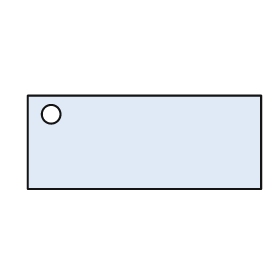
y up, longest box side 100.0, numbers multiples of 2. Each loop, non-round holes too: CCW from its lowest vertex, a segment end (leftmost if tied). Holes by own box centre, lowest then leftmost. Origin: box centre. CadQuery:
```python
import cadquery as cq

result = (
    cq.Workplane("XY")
    .moveTo(-50.0, -20.0)
    .lineTo(50.0, -20.0)
    .lineTo(50.0, 20.0)
    .lineTo(-50.0, 20.0)
    .close()
    .moveTo(-40.0, 12.0)
    .circle(4.0)
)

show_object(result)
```